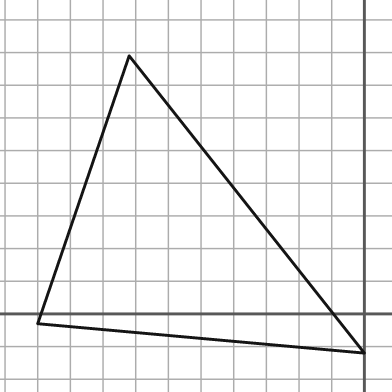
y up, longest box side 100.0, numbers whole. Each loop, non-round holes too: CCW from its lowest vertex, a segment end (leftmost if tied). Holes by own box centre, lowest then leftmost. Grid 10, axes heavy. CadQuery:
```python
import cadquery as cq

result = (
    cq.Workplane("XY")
    .moveTo(0.0, -12.0)
    .lineTo(-72.0, 79.0)
    .lineTo(-100.0, -3.0)
    .close()
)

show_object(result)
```